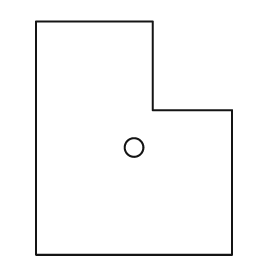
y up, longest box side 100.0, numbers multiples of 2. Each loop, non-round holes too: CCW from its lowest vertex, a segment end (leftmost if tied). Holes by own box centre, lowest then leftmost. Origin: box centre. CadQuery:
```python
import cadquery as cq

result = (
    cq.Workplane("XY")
    .moveTo(-42.0, -50.0)
    .lineTo(42.0, -50.0)
    .lineTo(42.0, 12.0)
    .lineTo(8.0, 12.0)
    .lineTo(8.0, 50.0)
    .lineTo(-42.0, 50.0)
    .close()
    .moveTo(0.0, -4.0)
    .circle(4.0)
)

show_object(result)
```